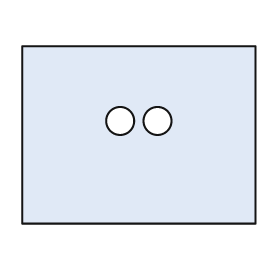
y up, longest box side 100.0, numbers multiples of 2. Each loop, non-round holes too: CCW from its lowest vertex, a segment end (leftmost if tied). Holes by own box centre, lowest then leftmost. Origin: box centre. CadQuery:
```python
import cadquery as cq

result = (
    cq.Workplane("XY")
    .moveTo(-50.0, -38.0)
    .lineTo(50.0, -38.0)
    .lineTo(50.0, 38.0)
    .lineTo(-50.0, 38.0)
    .close()
    .moveTo(-8.0, 6.0)
    .circle(6.0)
    .moveTo(8.0, 6.0)
    .circle(6.0)
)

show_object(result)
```